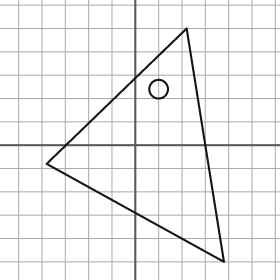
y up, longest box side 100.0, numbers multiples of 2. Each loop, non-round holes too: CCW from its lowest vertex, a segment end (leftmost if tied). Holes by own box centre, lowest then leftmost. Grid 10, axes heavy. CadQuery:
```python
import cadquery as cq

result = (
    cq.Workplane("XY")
    .moveTo(38.0, -50.0)
    .lineTo(22.0, 50.0)
    .lineTo(-38.0, -8.0)
    .close()
    .moveTo(10.0, 24.0)
    .circle(4.0)
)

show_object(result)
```